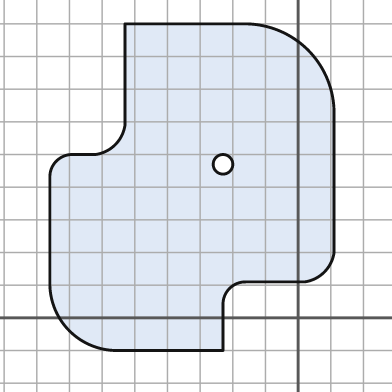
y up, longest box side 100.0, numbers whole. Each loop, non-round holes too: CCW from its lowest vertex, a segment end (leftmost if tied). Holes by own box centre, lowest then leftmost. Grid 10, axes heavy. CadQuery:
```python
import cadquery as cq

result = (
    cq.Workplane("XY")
    .moveTo(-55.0, -10.0)
    .lineTo(-23.0, -10.0)
    .lineTo(-23.0, 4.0)
    .threePointArc((-21.0, 9.0), (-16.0, 11.0))
    .lineTo(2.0, 11.0)
    .threePointArc((8.0, 14.0), (11.0, 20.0))
    .lineTo(11.0, 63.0)
    .threePointArc((3.0, 82.0), (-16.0, 90.0))
    .lineTo(-53.0, 90.0)
    .lineTo(-53.0, 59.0)
    .threePointArc((-56.0, 53.0), (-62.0, 50.0))
    .lineTo(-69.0, 50.0)
    .threePointArc((-74.0, 48.0), (-76.0, 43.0))
    .lineTo(-76.0, 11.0)
    .threePointArc((-70.0, -4.0), (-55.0, -10.0))
    .close()
    .moveTo(-23.0, 47.0)
    .circle(3.0)
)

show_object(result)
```